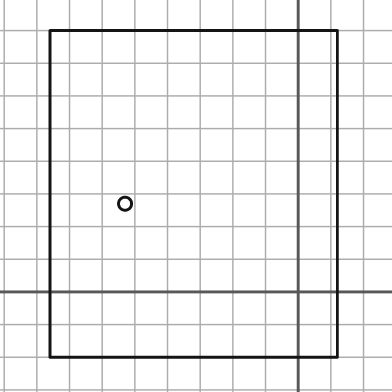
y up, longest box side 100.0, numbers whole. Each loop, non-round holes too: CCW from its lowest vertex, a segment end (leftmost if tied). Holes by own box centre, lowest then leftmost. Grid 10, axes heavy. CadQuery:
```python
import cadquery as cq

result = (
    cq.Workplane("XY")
    .moveTo(-76.0, -20.0)
    .lineTo(12.0, -20.0)
    .lineTo(12.0, 80.0)
    .lineTo(-76.0, 80.0)
    .close()
    .moveTo(-53.0, 27.0)
    .circle(2.0)
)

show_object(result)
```